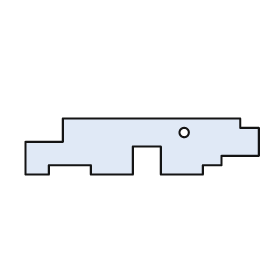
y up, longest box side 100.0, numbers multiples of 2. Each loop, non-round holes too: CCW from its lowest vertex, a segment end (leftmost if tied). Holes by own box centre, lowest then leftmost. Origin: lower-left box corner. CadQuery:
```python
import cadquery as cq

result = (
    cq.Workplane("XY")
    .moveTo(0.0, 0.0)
    .lineTo(10.0, 0.0)
    .lineTo(10.0, 4.0)
    .lineTo(28.0, 4.0)
    .lineTo(28.0, 0.0)
    .lineTo(46.0, 0.0)
    .lineTo(46.0, 12.0)
    .lineTo(58.0, 12.0)
    .lineTo(58.0, 0.0)
    .lineTo(76.0, 0.0)
    .lineTo(76.0, 4.0)
    .lineTo(84.0, 4.0)
    .lineTo(84.0, 8.0)
    .lineTo(100.0, 8.0)
    .lineTo(100.0, 20.0)
    .lineTo(92.0, 20.0)
    .lineTo(92.0, 24.0)
    .lineTo(16.0, 24.0)
    .lineTo(16.0, 14.0)
    .lineTo(0.0, 14.0)
    .close()
    .moveTo(68.0, 18.0)
    .circle(2.0)
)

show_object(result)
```